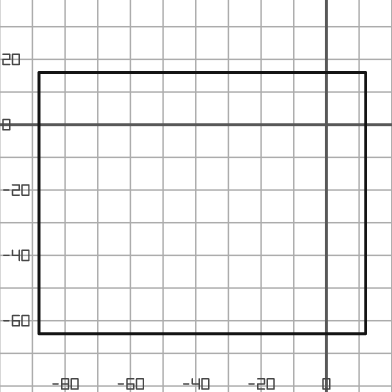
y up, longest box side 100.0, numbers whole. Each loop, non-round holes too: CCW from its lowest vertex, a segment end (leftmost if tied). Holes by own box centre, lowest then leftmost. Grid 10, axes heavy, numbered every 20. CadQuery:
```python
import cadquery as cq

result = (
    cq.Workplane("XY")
    .moveTo(-88.0, -64.0)
    .lineTo(12.0, -64.0)
    .lineTo(12.0, 16.0)
    .lineTo(-88.0, 16.0)
    .close()
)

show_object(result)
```